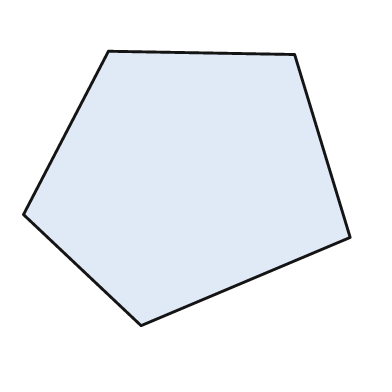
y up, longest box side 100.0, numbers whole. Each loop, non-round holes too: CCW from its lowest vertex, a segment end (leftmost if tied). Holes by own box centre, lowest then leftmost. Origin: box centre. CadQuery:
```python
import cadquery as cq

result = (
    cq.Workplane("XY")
    .moveTo(-14.0, -42.0)
    .lineTo(50.0, -15.0)
    .lineTo(33.0, 41.0)
    .lineTo(-24.0, 42.0)
    .lineTo(-50.0, -8.0)
    .close()
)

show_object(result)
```